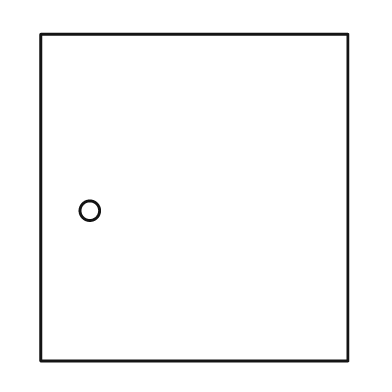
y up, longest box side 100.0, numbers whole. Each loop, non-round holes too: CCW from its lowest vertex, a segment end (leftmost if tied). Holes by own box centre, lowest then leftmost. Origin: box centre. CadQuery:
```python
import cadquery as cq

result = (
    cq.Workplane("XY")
    .moveTo(-47.0, -50.0)
    .lineTo(47.0, -50.0)
    .lineTo(47.0, 50.0)
    .lineTo(-47.0, 50.0)
    .close()
    .moveTo(-32.0, -4.0)
    .circle(3.0)
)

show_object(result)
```